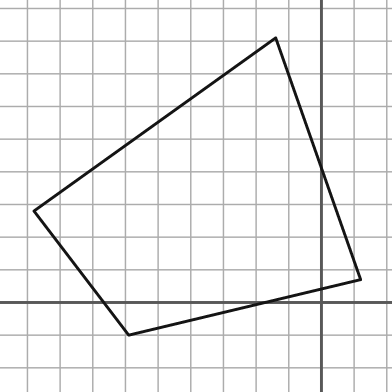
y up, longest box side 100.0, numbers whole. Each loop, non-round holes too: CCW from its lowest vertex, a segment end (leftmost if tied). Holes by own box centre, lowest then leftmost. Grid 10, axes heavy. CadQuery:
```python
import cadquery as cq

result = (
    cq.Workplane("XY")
    .moveTo(-59.0, -10.0)
    .lineTo(12.0, 7.0)
    .lineTo(-14.0, 81.0)
    .lineTo(-88.0, 28.0)
    .close()
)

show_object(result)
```